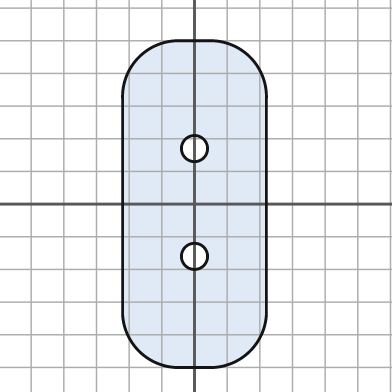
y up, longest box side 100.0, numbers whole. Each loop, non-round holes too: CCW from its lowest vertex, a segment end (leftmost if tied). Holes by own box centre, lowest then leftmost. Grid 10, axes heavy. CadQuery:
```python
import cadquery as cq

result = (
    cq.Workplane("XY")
    .moveTo(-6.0, -50.0)
    .lineTo(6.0, -50.0)
    .threePointArc((17.0, -45.0), (22.0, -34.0))
    .lineTo(22.0, 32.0)
    .threePointArc((17.0, 45.0), (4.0, 50.0))
    .lineTo(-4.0, 50.0)
    .threePointArc((-17.0, 45.0), (-22.0, 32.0))
    .lineTo(-22.0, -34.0)
    .threePointArc((-17.0, -45.0), (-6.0, -50.0))
    .close()
    .moveTo(0.0, -16.0)
    .circle(4.0)
    .moveTo(0.0, 17.0)
    .circle(4.0)
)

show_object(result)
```